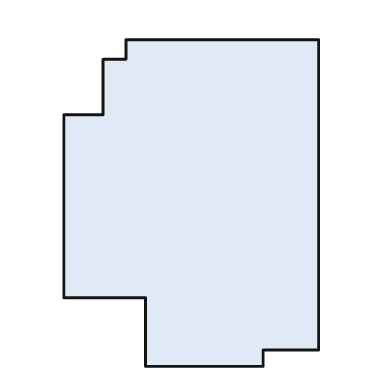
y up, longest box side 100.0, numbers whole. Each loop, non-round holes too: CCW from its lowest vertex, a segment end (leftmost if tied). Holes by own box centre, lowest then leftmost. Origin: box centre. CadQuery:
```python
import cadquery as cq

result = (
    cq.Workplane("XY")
    .moveTo(-14.0, -50.0)
    .lineTo(22.0, -50.0)
    .lineTo(22.0, -45.0)
    .lineTo(39.0, -45.0)
    .lineTo(39.0, 50.0)
    .lineTo(-20.0, 50.0)
    .lineTo(-20.0, 44.0)
    .lineTo(-27.0, 44.0)
    .lineTo(-27.0, 27.0)
    .lineTo(-39.0, 27.0)
    .lineTo(-39.0, -29.0)
    .lineTo(-14.0, -29.0)
    .close()
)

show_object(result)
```